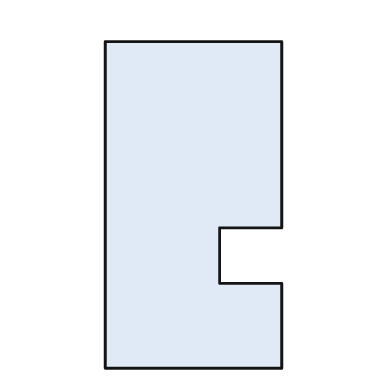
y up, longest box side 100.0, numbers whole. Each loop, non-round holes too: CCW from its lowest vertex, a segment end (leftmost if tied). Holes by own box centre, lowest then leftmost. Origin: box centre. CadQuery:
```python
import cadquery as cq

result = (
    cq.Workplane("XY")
    .moveTo(-27.0, -50.0)
    .lineTo(27.0, -50.0)
    .lineTo(27.0, -24.0)
    .lineTo(8.0, -24.0)
    .lineTo(8.0, -7.0)
    .lineTo(27.0, -7.0)
    .lineTo(27.0, 50.0)
    .lineTo(-27.0, 50.0)
    .close()
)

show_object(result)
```